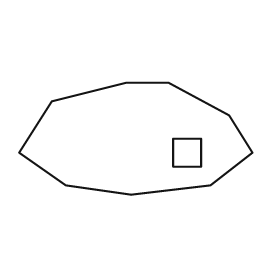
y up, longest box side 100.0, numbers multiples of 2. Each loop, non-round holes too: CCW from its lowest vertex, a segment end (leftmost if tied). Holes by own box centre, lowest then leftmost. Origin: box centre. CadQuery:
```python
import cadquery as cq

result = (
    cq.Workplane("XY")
    .moveTo(-2.0, -24.0)
    .lineTo(32.0, -20.0)
    .lineTo(50.0, -6.0)
    .lineTo(40.0, 10.0)
    .lineTo(14.0, 24.0)
    .lineTo(-4.0, 24.0)
    .lineTo(-36.0, 16.0)
    .lineTo(-50.0, -6.0)
    .lineTo(-30.0, -20.0)
    .close()
    .moveTo(16.0, -12.0)
    .lineTo(28.0, -12.0)
    .lineTo(28.0, 0.0)
    .lineTo(16.0, 0.0)
    .close()
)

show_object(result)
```